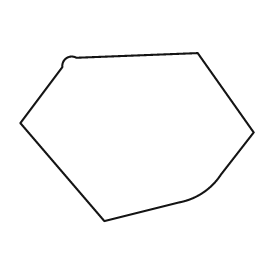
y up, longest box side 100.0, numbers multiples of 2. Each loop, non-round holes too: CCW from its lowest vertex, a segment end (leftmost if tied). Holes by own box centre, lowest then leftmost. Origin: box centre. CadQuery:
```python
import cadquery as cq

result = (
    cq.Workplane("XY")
    .moveTo(-14.0, -36.0)
    .lineTo(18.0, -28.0)
    .threePointArc((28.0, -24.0), (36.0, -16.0))
    .lineTo(50.0, 2.0)
    .lineTo(26.0, 36.0)
    .lineTo(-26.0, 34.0)
    .threePointArc((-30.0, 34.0), (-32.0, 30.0))
    .lineTo(-50.0, 6.0)
    .close()
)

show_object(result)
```